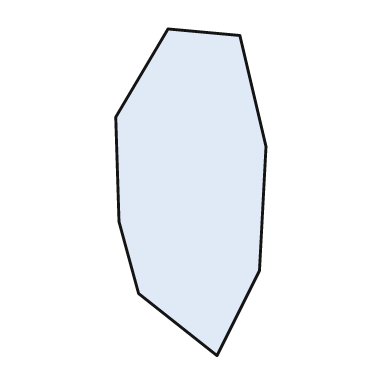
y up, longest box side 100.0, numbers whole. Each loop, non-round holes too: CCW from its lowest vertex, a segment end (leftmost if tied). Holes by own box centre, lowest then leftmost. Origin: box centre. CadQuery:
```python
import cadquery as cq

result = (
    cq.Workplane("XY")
    .moveTo(8.0, -50.0)
    .lineTo(21.0, -24.0)
    .lineTo(23.0, 14.0)
    .lineTo(15.0, 48.0)
    .lineTo(-7.0, 50.0)
    .lineTo(-23.0, 23.0)
    .lineTo(-22.0, -9.0)
    .lineTo(-16.0, -31.0)
    .close()
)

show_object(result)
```